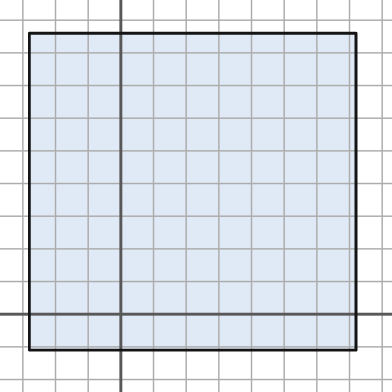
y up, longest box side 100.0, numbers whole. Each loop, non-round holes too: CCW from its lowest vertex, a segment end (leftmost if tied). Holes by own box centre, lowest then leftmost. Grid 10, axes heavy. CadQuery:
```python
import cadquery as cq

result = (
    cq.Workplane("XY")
    .moveTo(-28.0, -11.0)
    .lineTo(72.0, -11.0)
    .lineTo(72.0, 86.0)
    .lineTo(-28.0, 86.0)
    .close()
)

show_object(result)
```